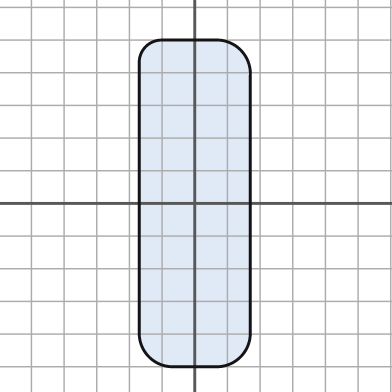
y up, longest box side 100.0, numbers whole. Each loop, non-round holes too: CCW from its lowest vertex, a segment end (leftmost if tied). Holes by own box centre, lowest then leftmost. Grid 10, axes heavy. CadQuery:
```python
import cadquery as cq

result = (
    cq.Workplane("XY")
    .moveTo(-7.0, -50.0)
    .lineTo(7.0, -50.0)
    .threePointArc((14.0, -47.0), (17.0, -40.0))
    .lineTo(17.0, 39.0)
    .threePointArc((14.0, 47.0), (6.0, 50.0))
    .lineTo(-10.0, 50.0)
    .threePointArc((-15.0, 48.0), (-17.0, 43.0))
    .lineTo(-17.0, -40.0)
    .threePointArc((-14.0, -47.0), (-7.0, -50.0))
    .close()
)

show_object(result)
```